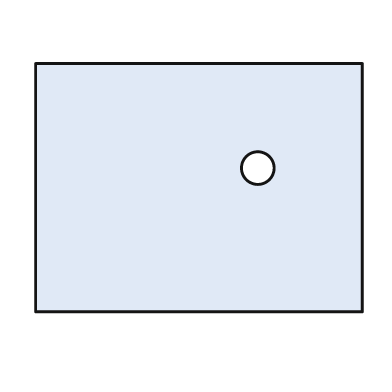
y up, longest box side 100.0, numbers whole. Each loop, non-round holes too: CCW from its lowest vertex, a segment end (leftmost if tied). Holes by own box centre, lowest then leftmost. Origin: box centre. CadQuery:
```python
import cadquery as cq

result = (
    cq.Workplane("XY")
    .moveTo(-50.0, -38.0)
    .lineTo(50.0, -38.0)
    .lineTo(50.0, 38.0)
    .lineTo(-50.0, 38.0)
    .close()
    .moveTo(18.0, 6.0)
    .circle(5.0)
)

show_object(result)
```